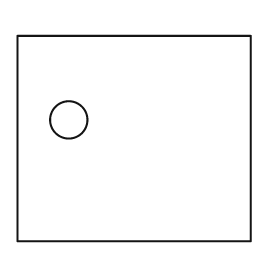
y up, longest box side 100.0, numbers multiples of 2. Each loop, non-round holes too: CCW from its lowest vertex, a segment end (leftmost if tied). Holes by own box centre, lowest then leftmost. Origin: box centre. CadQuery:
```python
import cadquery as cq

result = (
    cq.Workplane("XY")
    .moveTo(-50.0, -44.0)
    .lineTo(50.0, -44.0)
    .lineTo(50.0, 44.0)
    .lineTo(-50.0, 44.0)
    .close()
    .moveTo(-28.0, 8.0)
    .circle(8.0)
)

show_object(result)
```